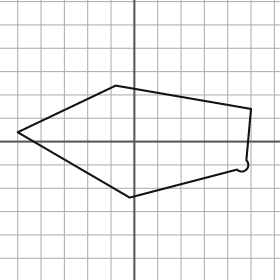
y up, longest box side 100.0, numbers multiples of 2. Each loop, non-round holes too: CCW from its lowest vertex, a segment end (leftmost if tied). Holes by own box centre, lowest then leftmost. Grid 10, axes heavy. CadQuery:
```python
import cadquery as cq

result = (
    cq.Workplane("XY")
    .moveTo(-2.0, -24.0)
    .lineTo(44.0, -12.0)
    .threePointArc((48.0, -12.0), (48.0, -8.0))
    .lineTo(50.0, 14.0)
    .lineTo(-8.0, 24.0)
    .lineTo(-50.0, 4.0)
    .close()
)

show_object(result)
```